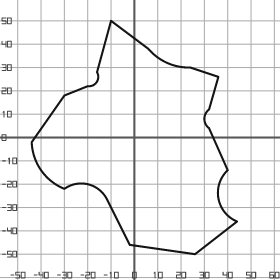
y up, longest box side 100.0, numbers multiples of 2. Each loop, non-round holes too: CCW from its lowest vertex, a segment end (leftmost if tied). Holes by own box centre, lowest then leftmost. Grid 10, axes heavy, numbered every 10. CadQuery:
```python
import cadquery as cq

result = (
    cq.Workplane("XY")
    .moveTo(26.0, -50.0)
    .lineTo(44.0, -36.0)
    .threePointArc((36.0, -26.0), (40.0, -14.0))
    .lineTo(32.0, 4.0)
    .threePointArc((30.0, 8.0), (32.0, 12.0))
    .lineTo(36.0, 26.0)
    .lineTo(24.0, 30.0)
    .threePointArc((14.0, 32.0), (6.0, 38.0))
    .lineTo(-10.0, 50.0)
    .lineTo(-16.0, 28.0)
    .threePointArc((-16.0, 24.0), (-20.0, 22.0))
    .lineTo(-30.0, 18.0)
    .lineTo(-44.0, -2.0)
    .threePointArc((-40.0, -14.0), (-30.0, -22.0))
    .threePointArc((-20.0, -20.0), (-12.0, -26.0))
    .lineTo(-2.0, -46.0)
    .close()
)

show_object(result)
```